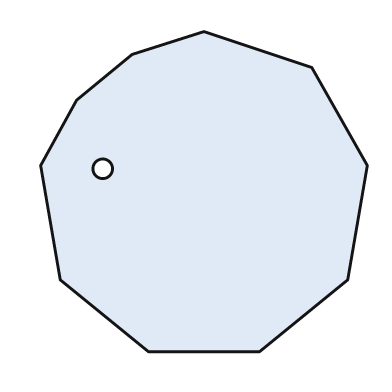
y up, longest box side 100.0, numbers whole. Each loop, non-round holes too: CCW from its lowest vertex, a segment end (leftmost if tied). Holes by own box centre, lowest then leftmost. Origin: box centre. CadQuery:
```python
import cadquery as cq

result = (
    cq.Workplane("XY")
    .moveTo(-17.0, -49.0)
    .lineTo(17.0, -49.0)
    .lineTo(44.0, -27.0)
    .lineTo(50.0, 8.0)
    .lineTo(33.0, 38.0)
    .lineTo(0.0, 49.0)
    .lineTo(-22.0, 42.0)
    .lineTo(-39.0, 28.0)
    .lineTo(-50.0, 8.0)
    .lineTo(-44.0, -27.0)
    .close()
    .moveTo(-31.0, 7.0)
    .circle(3.0)
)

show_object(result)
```